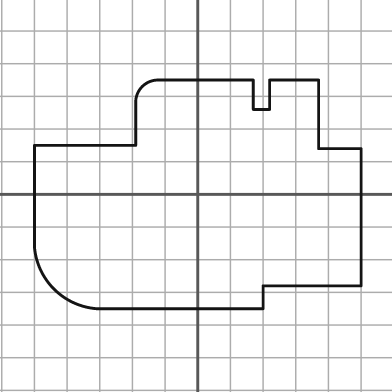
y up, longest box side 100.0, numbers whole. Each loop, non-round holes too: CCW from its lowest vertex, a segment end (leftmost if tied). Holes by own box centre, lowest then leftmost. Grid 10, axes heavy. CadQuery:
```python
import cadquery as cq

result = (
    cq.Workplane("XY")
    .moveTo(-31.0, -35.0)
    .lineTo(20.0, -35.0)
    .lineTo(20.0, -28.0)
    .lineTo(50.0, -28.0)
    .lineTo(50.0, 14.0)
    .lineTo(37.0, 14.0)
    .lineTo(37.0, 35.0)
    .lineTo(22.0, 35.0)
    .lineTo(22.0, 26.0)
    .lineTo(17.0, 26.0)
    .lineTo(17.0, 35.0)
    .lineTo(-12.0, 35.0)
    .threePointArc((-17.0, 33.0), (-19.0, 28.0))
    .lineTo(-19.0, 15.0)
    .lineTo(-50.0, 15.0)
    .lineTo(-50.0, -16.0)
    .threePointArc((-44.0, -29.0), (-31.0, -35.0))
    .close()
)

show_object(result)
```